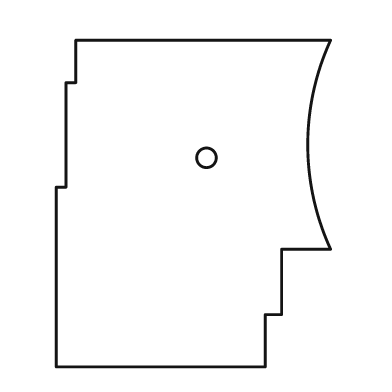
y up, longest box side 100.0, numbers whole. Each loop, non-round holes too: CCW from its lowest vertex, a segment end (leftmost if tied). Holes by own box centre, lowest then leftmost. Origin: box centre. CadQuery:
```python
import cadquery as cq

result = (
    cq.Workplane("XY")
    .moveTo(-42.0, -50.0)
    .lineTo(22.0, -50.0)
    .lineTo(22.0, -34.0)
    .lineTo(27.0, -34.0)
    .lineTo(27.0, -14.0)
    .lineTo(42.0, -14.0)
    .threePointArc((35.0, 18.0), (42.0, 50.0))
    .lineTo(-36.0, 50.0)
    .lineTo(-36.0, 37.0)
    .lineTo(-39.0, 37.0)
    .lineTo(-39.0, 5.0)
    .lineTo(-42.0, 5.0)
    .close()
    .moveTo(4.0, 14.0)
    .circle(3.0)
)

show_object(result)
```